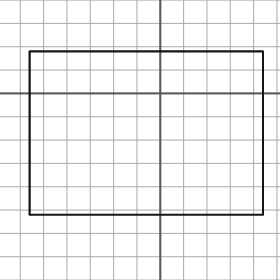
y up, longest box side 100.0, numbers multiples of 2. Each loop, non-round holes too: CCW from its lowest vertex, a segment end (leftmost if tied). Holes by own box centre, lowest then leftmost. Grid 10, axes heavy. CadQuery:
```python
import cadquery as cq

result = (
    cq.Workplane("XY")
    .moveTo(-56.0, -52.0)
    .lineTo(44.0, -52.0)
    .lineTo(44.0, 18.0)
    .lineTo(-56.0, 18.0)
    .close()
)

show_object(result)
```